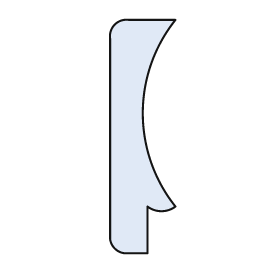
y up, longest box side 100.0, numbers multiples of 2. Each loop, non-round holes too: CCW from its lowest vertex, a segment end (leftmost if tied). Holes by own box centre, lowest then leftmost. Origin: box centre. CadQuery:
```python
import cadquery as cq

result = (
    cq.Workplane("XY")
    .moveTo(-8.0, -50.0)
    .lineTo(2.0, -50.0)
    .lineTo(2.0, -30.0)
    .threePointArc((8.0, -32.0), (14.0, -30.0))
    .threePointArc((0.0, 10.0), (14.0, 50.0))
    .lineTo(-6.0, 50.0)
    .threePointArc((-12.0, 48.0), (-14.0, 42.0))
    .lineTo(-14.0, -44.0)
    .threePointArc((-12.0, -48.0), (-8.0, -50.0))
    .close()
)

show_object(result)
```